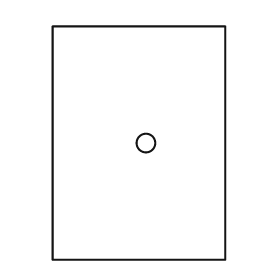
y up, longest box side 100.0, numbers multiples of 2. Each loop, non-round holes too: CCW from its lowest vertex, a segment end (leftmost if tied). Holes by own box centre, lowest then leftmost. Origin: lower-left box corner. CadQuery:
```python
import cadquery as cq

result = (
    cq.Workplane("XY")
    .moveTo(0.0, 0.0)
    .lineTo(74.0, 0.0)
    .lineTo(74.0, 100.0)
    .lineTo(0.0, 100.0)
    .close()
    .moveTo(40.0, 50.0)
    .circle(4.0)
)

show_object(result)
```